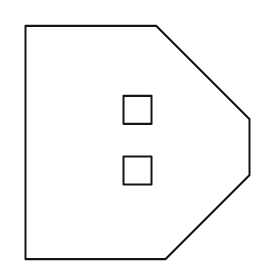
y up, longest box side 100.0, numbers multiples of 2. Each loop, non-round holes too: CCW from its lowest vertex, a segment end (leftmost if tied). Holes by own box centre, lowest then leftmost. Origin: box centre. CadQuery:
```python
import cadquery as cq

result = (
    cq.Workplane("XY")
    .moveTo(-48.0, -50.0)
    .lineTo(12.0, -50.0)
    .lineTo(48.0, -14.0)
    .lineTo(48.0, 10.0)
    .lineTo(8.0, 50.0)
    .lineTo(-48.0, 50.0)
    .close()
    .moveTo(-6.0, -18.0)
    .lineTo(6.0, -18.0)
    .lineTo(6.0, -6.0)
    .lineTo(-6.0, -6.0)
    .close()
    .moveTo(-6.0, 8.0)
    .lineTo(6.0, 8.0)
    .lineTo(6.0, 20.0)
    .lineTo(-6.0, 20.0)
    .close()
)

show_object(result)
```